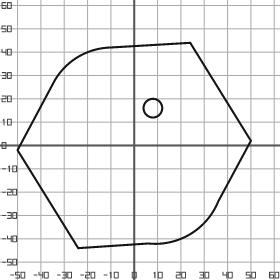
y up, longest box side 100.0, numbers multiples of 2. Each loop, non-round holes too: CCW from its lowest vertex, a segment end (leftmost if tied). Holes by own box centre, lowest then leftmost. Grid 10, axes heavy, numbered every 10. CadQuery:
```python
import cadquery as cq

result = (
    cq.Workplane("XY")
    .moveTo(-24.0, -44.0)
    .lineTo(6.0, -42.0)
    .threePointArc((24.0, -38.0), (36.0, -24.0))
    .lineTo(50.0, 2.0)
    .lineTo(24.0, 44.0)
    .lineTo(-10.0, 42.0)
    .threePointArc((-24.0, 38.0), (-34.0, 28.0))
    .lineTo(-50.0, -2.0)
    .close()
    .moveTo(8.0, 16.0)
    .circle(4.0)
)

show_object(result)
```